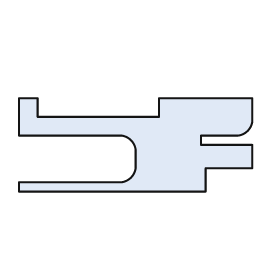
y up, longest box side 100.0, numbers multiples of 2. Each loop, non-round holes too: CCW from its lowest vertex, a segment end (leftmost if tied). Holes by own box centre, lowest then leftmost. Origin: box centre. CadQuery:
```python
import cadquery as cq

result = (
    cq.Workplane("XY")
    .moveTo(-50.0, -20.0)
    .lineTo(30.0, -20.0)
    .lineTo(30.0, -10.0)
    .lineTo(50.0, -10.0)
    .lineTo(50.0, 0.0)
    .lineTo(28.0, 0.0)
    .lineTo(28.0, 4.0)
    .lineTo(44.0, 4.0)
    .threePointArc((48.0, 6.0), (50.0, 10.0))
    .lineTo(50.0, 20.0)
    .lineTo(10.0, 20.0)
    .lineTo(10.0, 12.0)
    .lineTo(-42.0, 12.0)
    .lineTo(-42.0, 20.0)
    .lineTo(-50.0, 20.0)
    .lineTo(-50.0, 4.0)
    .lineTo(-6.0, 4.0)
    .threePointArc((-2.0, 2.0), (0.0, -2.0))
    .lineTo(0.0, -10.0)
    .threePointArc((-2.0, -14.0), (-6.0, -16.0))
    .lineTo(-50.0, -16.0)
    .close()
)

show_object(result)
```